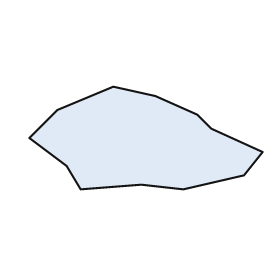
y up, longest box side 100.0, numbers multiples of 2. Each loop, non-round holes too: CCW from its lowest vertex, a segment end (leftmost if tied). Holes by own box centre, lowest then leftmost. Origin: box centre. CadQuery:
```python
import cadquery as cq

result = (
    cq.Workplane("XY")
    .moveTo(-28.0, -22.0)
    .lineTo(-2.0, -20.0)
    .lineTo(16.0, -22.0)
    .lineTo(42.0, -16.0)
    .lineTo(50.0, -6.0)
    .lineTo(28.0, 4.0)
    .lineTo(22.0, 10.0)
    .lineTo(4.0, 18.0)
    .lineTo(-14.0, 22.0)
    .lineTo(-38.0, 12.0)
    .lineTo(-50.0, 0.0)
    .lineTo(-34.0, -12.0)
    .close()
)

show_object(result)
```